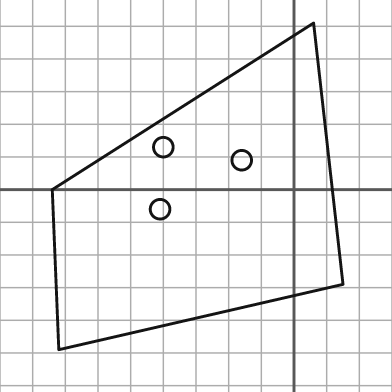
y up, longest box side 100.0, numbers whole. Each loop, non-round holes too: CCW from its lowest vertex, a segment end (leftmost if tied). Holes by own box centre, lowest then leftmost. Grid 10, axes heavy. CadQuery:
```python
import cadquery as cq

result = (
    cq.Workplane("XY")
    .moveTo(-72.0, -49.0)
    .lineTo(15.0, -29.0)
    .lineTo(6.0, 51.0)
    .lineTo(-74.0, 0.0)
    .close()
    .moveTo(-41.0, -6.0)
    .circle(3.0)
    .moveTo(-16.0, 9.0)
    .circle(3.0)
    .moveTo(-40.0, 13.0)
    .circle(3.0)
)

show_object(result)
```